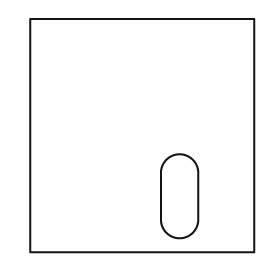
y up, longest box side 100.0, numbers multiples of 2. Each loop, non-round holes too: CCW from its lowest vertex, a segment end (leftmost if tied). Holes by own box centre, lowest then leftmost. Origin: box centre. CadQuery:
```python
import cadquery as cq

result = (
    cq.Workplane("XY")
    .moveTo(-48.0, -50.0)
    .lineTo(48.0, -50.0)
    .lineTo(48.0, 50.0)
    .lineTo(-48.0, 50.0)
    .close()
    .moveTo(8.0, -36.0)
    .threePointArc((16.0, -44.0), (24.0, -36.0))
    .lineTo(24.0, -16.0)
    .threePointArc((16.0, -8.0), (8.0, -16.0))
    .close()
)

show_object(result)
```